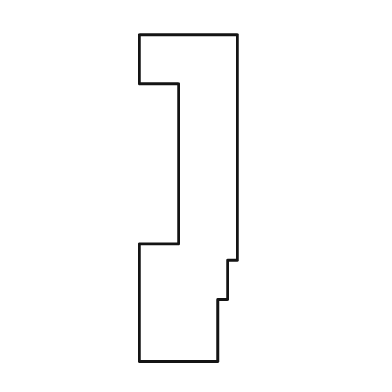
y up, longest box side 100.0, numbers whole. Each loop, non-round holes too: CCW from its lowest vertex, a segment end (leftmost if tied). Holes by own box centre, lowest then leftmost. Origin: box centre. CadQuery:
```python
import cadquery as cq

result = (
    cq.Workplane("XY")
    .moveTo(-15.0, -50.0)
    .lineTo(9.0, -50.0)
    .lineTo(9.0, -31.0)
    .lineTo(12.0, -31.0)
    .lineTo(12.0, -19.0)
    .lineTo(15.0, -19.0)
    .lineTo(15.0, 50.0)
    .lineTo(-15.0, 50.0)
    .lineTo(-15.0, 35.0)
    .lineTo(-3.0, 35.0)
    .lineTo(-3.0, -14.0)
    .lineTo(-15.0, -14.0)
    .close()
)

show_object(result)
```